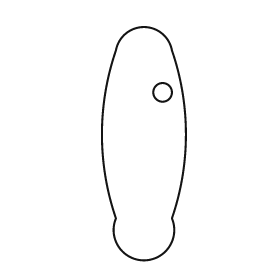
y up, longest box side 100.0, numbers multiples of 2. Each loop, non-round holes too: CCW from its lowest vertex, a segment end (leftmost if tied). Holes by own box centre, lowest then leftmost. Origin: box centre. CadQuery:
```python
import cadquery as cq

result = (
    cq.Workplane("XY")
    .moveTo(-12.0, -32.0)
    .threePointArc((0.0, -50.0), (12.0, -32.0))
    .threePointArc((18.0, 4.0), (12.0, 40.0))
    .threePointArc((0.0, 50.0), (-12.0, 40.0))
    .threePointArc((-18.0, 4.0), (-12.0, -32.0))
    .close()
    .moveTo(8.0, 22.0)
    .circle(4.0)
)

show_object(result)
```